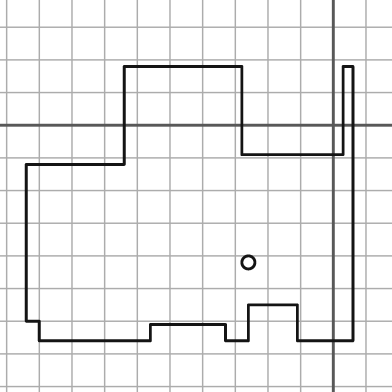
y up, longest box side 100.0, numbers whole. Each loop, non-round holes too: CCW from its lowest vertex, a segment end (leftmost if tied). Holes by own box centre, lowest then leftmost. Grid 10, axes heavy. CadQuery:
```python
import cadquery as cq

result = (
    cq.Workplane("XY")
    .moveTo(-90.0, -66.0)
    .lineTo(-56.0, -66.0)
    .lineTo(-56.0, -61.0)
    .lineTo(-33.0, -61.0)
    .lineTo(-33.0, -66.0)
    .lineTo(-26.0, -66.0)
    .lineTo(-26.0, -55.0)
    .lineTo(-11.0, -55.0)
    .lineTo(-11.0, -66.0)
    .lineTo(6.0, -66.0)
    .lineTo(6.0, 18.0)
    .lineTo(3.0, 18.0)
    .lineTo(3.0, -9.0)
    .lineTo(-28.0, -9.0)
    .lineTo(-28.0, 18.0)
    .lineTo(-64.0, 18.0)
    .lineTo(-64.0, -12.0)
    .lineTo(-94.0, -12.0)
    .lineTo(-94.0, -60.0)
    .lineTo(-90.0, -60.0)
    .close()
    .moveTo(-26.0, -42.0)
    .circle(2.0)
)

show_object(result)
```